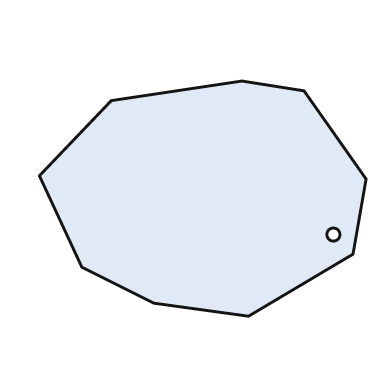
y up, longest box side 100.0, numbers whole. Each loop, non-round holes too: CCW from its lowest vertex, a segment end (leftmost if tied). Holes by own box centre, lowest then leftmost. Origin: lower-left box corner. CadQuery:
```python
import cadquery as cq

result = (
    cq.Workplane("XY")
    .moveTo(64.0, 0.0)
    .lineTo(96.0, 19.0)
    .lineTo(100.0, 42.0)
    .lineTo(81.0, 69.0)
    .lineTo(62.0, 72.0)
    .lineTo(22.0, 66.0)
    .lineTo(0.0, 43.0)
    .lineTo(13.0, 15.0)
    .lineTo(35.0, 4.0)
    .close()
    .moveTo(90.0, 25.0)
    .circle(2.0)
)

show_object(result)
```